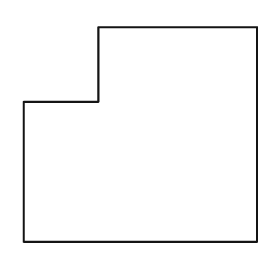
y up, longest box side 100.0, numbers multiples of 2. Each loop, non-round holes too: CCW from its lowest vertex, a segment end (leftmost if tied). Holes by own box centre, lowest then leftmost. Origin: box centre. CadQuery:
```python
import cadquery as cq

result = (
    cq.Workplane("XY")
    .moveTo(-50.0, -46.0)
    .lineTo(50.0, -46.0)
    .lineTo(50.0, 46.0)
    .lineTo(-18.0, 46.0)
    .lineTo(-18.0, 14.0)
    .lineTo(-50.0, 14.0)
    .close()
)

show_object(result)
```